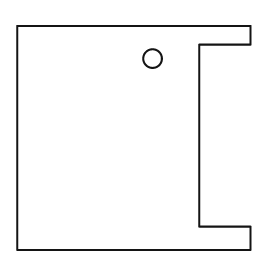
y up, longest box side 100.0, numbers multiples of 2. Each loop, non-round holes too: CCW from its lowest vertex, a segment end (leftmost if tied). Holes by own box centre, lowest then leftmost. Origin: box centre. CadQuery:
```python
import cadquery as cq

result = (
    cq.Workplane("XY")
    .moveTo(-50.0, -48.0)
    .lineTo(50.0, -48.0)
    .lineTo(50.0, -38.0)
    .lineTo(28.0, -38.0)
    .lineTo(28.0, 40.0)
    .lineTo(50.0, 40.0)
    .lineTo(50.0, 48.0)
    .lineTo(-50.0, 48.0)
    .close()
    .moveTo(8.0, 34.0)
    .circle(4.0)
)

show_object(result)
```